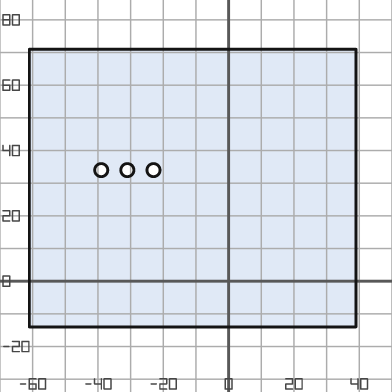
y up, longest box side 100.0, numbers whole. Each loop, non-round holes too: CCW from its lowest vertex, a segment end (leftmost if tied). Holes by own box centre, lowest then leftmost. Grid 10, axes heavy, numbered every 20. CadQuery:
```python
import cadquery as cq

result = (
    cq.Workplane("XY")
    .moveTo(-61.0, -14.0)
    .lineTo(39.0, -14.0)
    .lineTo(39.0, 71.0)
    .lineTo(-61.0, 71.0)
    .close()
    .moveTo(-39.0, 34.0)
    .circle(2.0)
    .moveTo(-31.0, 34.0)
    .circle(2.0)
    .moveTo(-23.0, 34.0)
    .circle(2.0)
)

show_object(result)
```